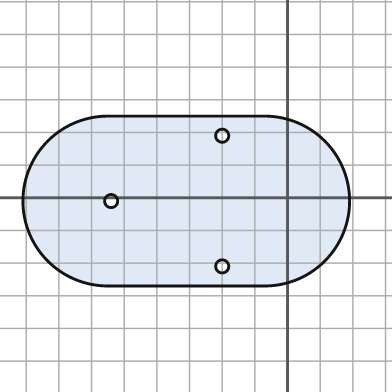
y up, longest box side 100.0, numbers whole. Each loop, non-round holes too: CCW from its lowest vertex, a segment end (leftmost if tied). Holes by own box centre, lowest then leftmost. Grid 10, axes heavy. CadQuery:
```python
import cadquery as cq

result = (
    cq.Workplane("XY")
    .moveTo(-55.0, -27.0)
    .lineTo(-7.0, -27.0)
    .threePointArc((19.0, -1.0), (-7.0, 25.0))
    .lineTo(-55.0, 25.0)
    .threePointArc((-81.0, -1.0), (-55.0, -27.0))
    .close()
    .moveTo(-20.0, -21.0)
    .circle(2.0)
    .moveTo(-54.0, -1.0)
    .circle(2.0)
    .moveTo(-20.0, 19.0)
    .circle(2.0)
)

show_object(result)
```